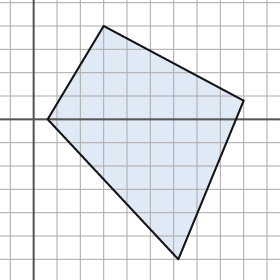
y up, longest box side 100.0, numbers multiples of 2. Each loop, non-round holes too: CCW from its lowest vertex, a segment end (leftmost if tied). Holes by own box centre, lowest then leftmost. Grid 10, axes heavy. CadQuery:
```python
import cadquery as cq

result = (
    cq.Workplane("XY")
    .moveTo(62.0, -60.0)
    .lineTo(90.0, 8.0)
    .lineTo(30.0, 40.0)
    .lineTo(6.0, 0.0)
    .close()
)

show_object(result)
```